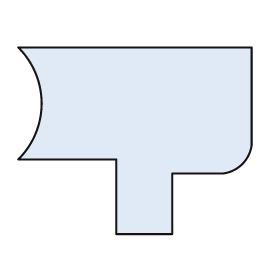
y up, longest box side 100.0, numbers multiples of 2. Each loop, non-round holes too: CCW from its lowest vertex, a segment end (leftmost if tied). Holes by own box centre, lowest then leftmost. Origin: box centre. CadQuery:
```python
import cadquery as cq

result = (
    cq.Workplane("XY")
    .moveTo(-8.0, -40.0)
    .lineTo(16.0, -40.0)
    .lineTo(16.0, -14.0)
    .lineTo(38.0, -14.0)
    .threePointArc((46.0, -10.0), (50.0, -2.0))
    .lineTo(50.0, 40.0)
    .lineTo(-50.0, 40.0)
    .threePointArc((-40.0, 16.0), (-50.0, -8.0))
    .lineTo(-8.0, -8.0)
    .close()
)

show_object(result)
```